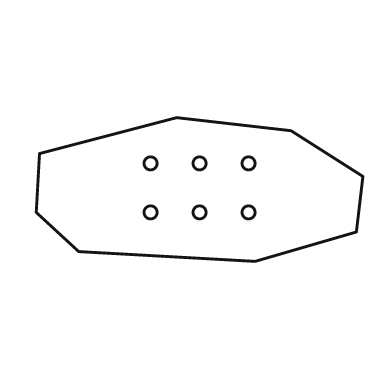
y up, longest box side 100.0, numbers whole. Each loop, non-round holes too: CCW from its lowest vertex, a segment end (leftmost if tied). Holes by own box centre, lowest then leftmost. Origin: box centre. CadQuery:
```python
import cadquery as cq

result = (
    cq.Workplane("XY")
    .moveTo(17.0, -22.0)
    .lineTo(48.0, -13.0)
    .lineTo(50.0, 4.0)
    .lineTo(28.0, 18.0)
    .lineTo(-7.0, 22.0)
    .lineTo(-49.0, 11.0)
    .lineTo(-50.0, -7.0)
    .lineTo(-37.0, -19.0)
    .close()
    .moveTo(-15.0, -7.0)
    .circle(2.0)
    .moveTo(0.0, -7.0)
    .circle(2.0)
    .moveTo(15.0, -7.0)
    .circle(2.0)
    .moveTo(-15.0, 8.0)
    .circle(2.0)
    .moveTo(0.0, 8.0)
    .circle(2.0)
    .moveTo(15.0, 8.0)
    .circle(2.0)
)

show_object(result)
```